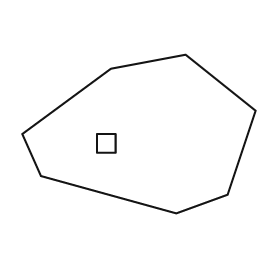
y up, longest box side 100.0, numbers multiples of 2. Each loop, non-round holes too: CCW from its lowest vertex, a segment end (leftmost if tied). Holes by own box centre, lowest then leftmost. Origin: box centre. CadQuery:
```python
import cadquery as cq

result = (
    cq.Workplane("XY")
    .moveTo(16.0, -34.0)
    .lineTo(38.0, -26.0)
    .lineTo(50.0, 10.0)
    .lineTo(20.0, 34.0)
    .lineTo(-12.0, 28.0)
    .lineTo(-50.0, 0.0)
    .lineTo(-42.0, -18.0)
    .close()
    .moveTo(-18.0, -8.0)
    .lineTo(-10.0, -8.0)
    .lineTo(-10.0, 0.0)
    .lineTo(-18.0, 0.0)
    .close()
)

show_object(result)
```